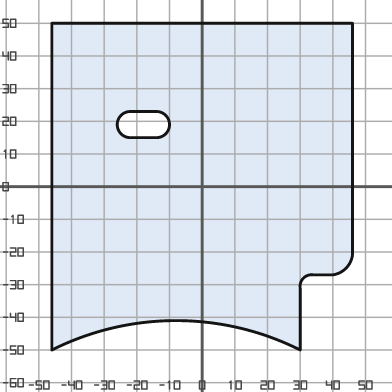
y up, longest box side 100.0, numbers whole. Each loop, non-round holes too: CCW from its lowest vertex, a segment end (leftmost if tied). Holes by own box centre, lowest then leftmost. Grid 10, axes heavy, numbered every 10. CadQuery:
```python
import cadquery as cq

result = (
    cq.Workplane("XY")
    .moveTo(-46.0, -50.0)
    .threePointArc((-8.0, -41.0), (30.0, -50.0))
    .lineTo(30.0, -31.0)
    .threePointArc((31.0, -28.0), (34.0, -27.0))
    .lineTo(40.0, -27.0)
    .threePointArc((44.0, -25.0), (46.0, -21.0))
    .lineTo(46.0, 50.0)
    .lineTo(-46.0, 50.0)
    .close()
    .moveTo(-22.0, 15.0)
    .lineTo(-14.0, 15.0)
    .threePointArc((-10.0, 19.0), (-14.0, 23.0))
    .lineTo(-22.0, 23.0)
    .threePointArc((-26.0, 19.0), (-22.0, 15.0))
    .close()
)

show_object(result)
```